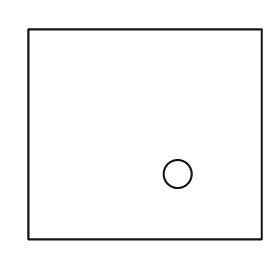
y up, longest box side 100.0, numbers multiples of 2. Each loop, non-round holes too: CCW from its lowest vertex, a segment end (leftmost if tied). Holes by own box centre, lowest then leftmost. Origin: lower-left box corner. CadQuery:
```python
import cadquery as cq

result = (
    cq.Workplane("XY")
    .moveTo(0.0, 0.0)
    .lineTo(100.0, 0.0)
    .lineTo(100.0, 90.0)
    .lineTo(0.0, 90.0)
    .close()
    .moveTo(64.0, 28.0)
    .circle(6.0)
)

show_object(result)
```